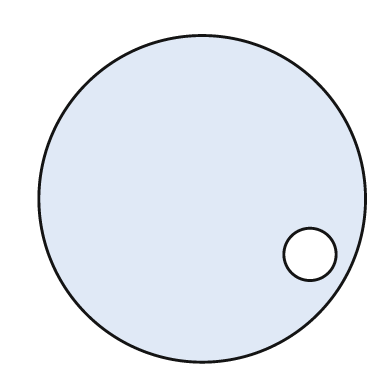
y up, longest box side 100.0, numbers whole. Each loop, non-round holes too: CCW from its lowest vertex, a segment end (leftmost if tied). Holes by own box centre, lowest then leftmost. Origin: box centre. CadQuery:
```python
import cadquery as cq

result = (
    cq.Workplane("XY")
    .moveTo(0.0, 0.0)
    .circle(50.0)
    .moveTo(33.0, -17.0)
    .circle(8.0)
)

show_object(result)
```